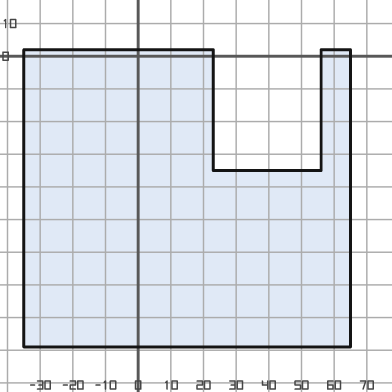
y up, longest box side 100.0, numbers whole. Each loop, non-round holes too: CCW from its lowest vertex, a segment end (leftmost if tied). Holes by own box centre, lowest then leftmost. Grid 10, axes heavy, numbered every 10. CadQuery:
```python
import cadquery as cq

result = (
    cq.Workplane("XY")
    .moveTo(-35.0, -89.0)
    .lineTo(65.0, -89.0)
    .lineTo(65.0, 2.0)
    .lineTo(56.0, 2.0)
    .lineTo(56.0, -35.0)
    .lineTo(23.0, -35.0)
    .lineTo(23.0, 2.0)
    .lineTo(-35.0, 2.0)
    .close()
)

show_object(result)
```